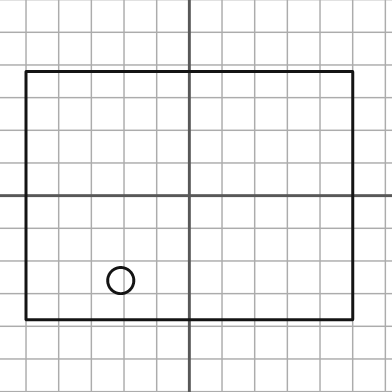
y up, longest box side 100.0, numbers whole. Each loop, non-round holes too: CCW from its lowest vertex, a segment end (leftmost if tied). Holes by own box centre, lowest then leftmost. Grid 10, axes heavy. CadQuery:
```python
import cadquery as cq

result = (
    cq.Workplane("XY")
    .moveTo(-50.0, -38.0)
    .lineTo(50.0, -38.0)
    .lineTo(50.0, 38.0)
    .lineTo(-50.0, 38.0)
    .close()
    .moveTo(-21.0, -26.0)
    .circle(4.0)
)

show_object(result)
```